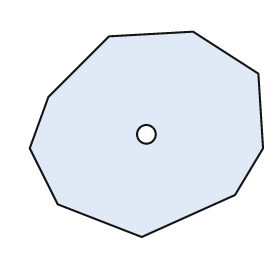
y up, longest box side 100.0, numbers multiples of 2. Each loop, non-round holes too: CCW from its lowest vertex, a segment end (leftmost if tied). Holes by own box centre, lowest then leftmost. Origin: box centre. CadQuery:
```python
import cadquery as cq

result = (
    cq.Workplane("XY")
    .moveTo(-2.0, -44.0)
    .lineTo(38.0, -26.0)
    .lineTo(50.0, -6.0)
    .lineTo(48.0, 26.0)
    .lineTo(20.0, 44.0)
    .lineTo(-16.0, 42.0)
    .lineTo(-42.0, 16.0)
    .lineTo(-50.0, -6.0)
    .lineTo(-38.0, -30.0)
    .close()
    .moveTo(0.0, 0.0)
    .circle(4.0)
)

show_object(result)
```